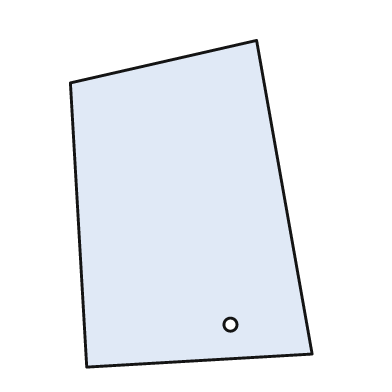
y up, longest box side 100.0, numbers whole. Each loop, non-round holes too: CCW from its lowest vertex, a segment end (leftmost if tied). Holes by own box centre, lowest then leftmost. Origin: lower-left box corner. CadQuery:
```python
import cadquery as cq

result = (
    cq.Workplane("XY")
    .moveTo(5.0, 0.0)
    .lineTo(74.0, 4.0)
    .lineTo(57.0, 100.0)
    .lineTo(0.0, 87.0)
    .close()
    .moveTo(49.0, 13.0)
    .circle(2.0)
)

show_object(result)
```